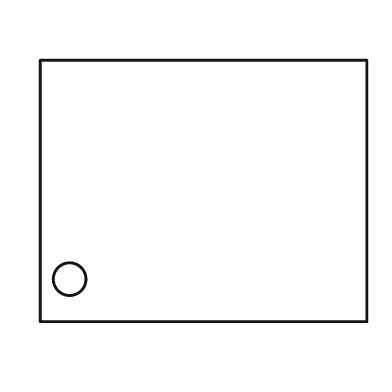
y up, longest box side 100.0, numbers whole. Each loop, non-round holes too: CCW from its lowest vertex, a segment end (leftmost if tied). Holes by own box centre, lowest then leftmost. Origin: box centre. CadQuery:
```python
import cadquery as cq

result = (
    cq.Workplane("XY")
    .moveTo(-50.0, -40.0)
    .lineTo(50.0, -40.0)
    .lineTo(50.0, 40.0)
    .lineTo(-50.0, 40.0)
    .close()
    .moveTo(-41.0, -27.0)
    .circle(5.0)
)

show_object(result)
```